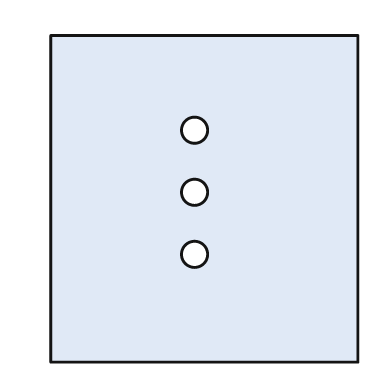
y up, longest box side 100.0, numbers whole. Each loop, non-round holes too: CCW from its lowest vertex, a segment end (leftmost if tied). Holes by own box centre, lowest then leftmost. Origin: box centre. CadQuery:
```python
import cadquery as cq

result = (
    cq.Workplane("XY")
    .moveTo(-47.0, -50.0)
    .lineTo(47.0, -50.0)
    .lineTo(47.0, 50.0)
    .lineTo(-47.0, 50.0)
    .close()
    .moveTo(-3.0, -17.0)
    .circle(4.0)
    .moveTo(-3.0, 2.0)
    .circle(4.0)
    .moveTo(-3.0, 21.0)
    .circle(4.0)
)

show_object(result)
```